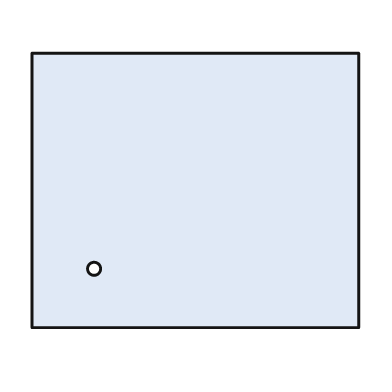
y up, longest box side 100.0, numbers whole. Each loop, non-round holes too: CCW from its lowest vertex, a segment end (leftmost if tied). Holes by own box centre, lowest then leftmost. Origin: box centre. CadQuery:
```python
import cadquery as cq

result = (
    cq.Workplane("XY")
    .moveTo(-50.0, -42.0)
    .lineTo(50.0, -42.0)
    .lineTo(50.0, 42.0)
    .lineTo(-50.0, 42.0)
    .close()
    .moveTo(-31.0, -24.0)
    .circle(2.0)
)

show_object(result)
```